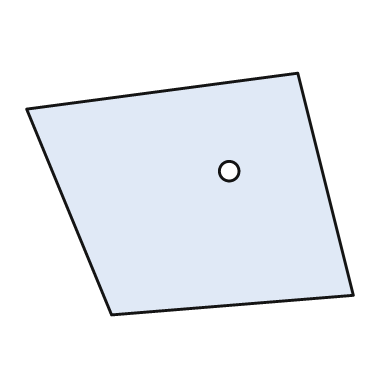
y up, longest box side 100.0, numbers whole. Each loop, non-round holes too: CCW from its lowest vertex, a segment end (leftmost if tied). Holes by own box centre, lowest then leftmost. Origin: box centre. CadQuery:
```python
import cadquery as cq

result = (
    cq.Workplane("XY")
    .moveTo(-24.0, -37.0)
    .lineTo(50.0, -31.0)
    .lineTo(33.0, 37.0)
    .lineTo(-50.0, 26.0)
    .close()
    .moveTo(12.0, 7.0)
    .circle(3.0)
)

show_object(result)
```